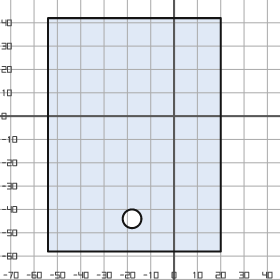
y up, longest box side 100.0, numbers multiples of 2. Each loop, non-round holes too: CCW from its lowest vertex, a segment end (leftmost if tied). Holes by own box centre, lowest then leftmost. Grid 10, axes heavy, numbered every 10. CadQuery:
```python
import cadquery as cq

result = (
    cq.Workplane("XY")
    .moveTo(-54.0, -58.0)
    .lineTo(20.0, -58.0)
    .lineTo(20.0, 42.0)
    .lineTo(-54.0, 42.0)
    .close()
    .moveTo(-18.0, -44.0)
    .circle(4.0)
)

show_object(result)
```